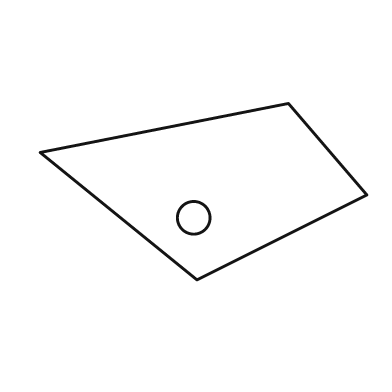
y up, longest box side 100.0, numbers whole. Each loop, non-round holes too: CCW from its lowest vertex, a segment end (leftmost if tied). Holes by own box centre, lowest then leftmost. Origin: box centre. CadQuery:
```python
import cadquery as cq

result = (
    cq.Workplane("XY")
    .moveTo(-2.0, -27.0)
    .lineTo(50.0, -1.0)
    .lineTo(26.0, 27.0)
    .lineTo(-50.0, 12.0)
    .close()
    .moveTo(-3.0, -8.0)
    .circle(5.0)
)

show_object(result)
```